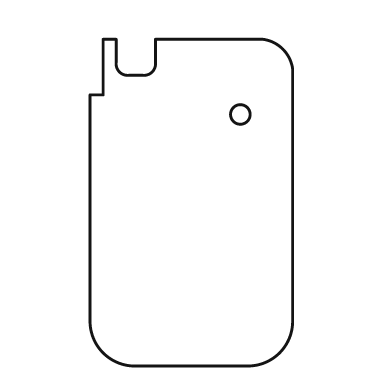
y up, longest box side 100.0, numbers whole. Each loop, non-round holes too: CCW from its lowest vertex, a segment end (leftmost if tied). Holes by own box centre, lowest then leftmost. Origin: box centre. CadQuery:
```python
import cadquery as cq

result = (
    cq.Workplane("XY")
    .moveTo(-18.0, -50.0)
    .lineTo(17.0, -50.0)
    .threePointArc((27.0, -46.0), (31.0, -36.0))
    .lineTo(31.0, 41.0)
    .threePointArc((28.0, 47.0), (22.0, 50.0))
    .lineTo(-11.0, 50.0)
    .lineTo(-11.0, 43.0)
    .threePointArc((-12.0, 40.0), (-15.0, 39.0))
    .lineTo(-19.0, 39.0)
    .threePointArc((-22.0, 40.0), (-23.0, 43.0))
    .lineTo(-23.0, 50.0)
    .lineTo(-27.0, 50.0)
    .lineTo(-27.0, 33.0)
    .lineTo(-31.0, 33.0)
    .lineTo(-31.0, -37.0)
    .threePointArc((-27.0, -46.0), (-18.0, -50.0))
    .close()
    .moveTo(15.0, 27.0)
    .circle(3.0)
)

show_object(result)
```